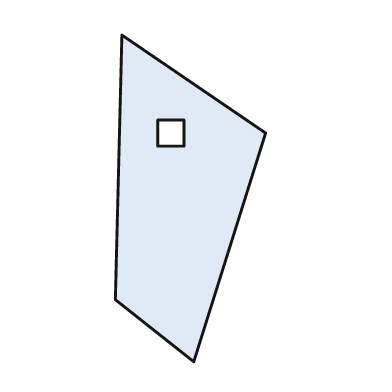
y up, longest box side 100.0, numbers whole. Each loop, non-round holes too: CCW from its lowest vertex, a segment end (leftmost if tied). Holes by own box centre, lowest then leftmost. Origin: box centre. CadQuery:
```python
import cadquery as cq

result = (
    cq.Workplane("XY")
    .moveTo(1.0, -50.0)
    .lineTo(23.0, 20.0)
    .lineTo(-21.0, 50.0)
    .lineTo(-23.0, -31.0)
    .close()
    .moveTo(-10.0, 16.0)
    .lineTo(-2.0, 16.0)
    .lineTo(-2.0, 24.0)
    .lineTo(-10.0, 24.0)
    .close()
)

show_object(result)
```